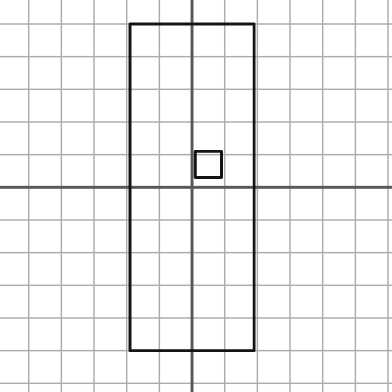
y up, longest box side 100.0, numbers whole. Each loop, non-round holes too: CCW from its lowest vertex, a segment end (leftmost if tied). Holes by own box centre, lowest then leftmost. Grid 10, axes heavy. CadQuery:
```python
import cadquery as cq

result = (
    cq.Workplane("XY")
    .moveTo(-19.0, -50.0)
    .lineTo(19.0, -50.0)
    .lineTo(19.0, 50.0)
    .lineTo(-19.0, 50.0)
    .close()
    .moveTo(1.0, 3.0)
    .lineTo(9.0, 3.0)
    .lineTo(9.0, 11.0)
    .lineTo(1.0, 11.0)
    .close()
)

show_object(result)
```